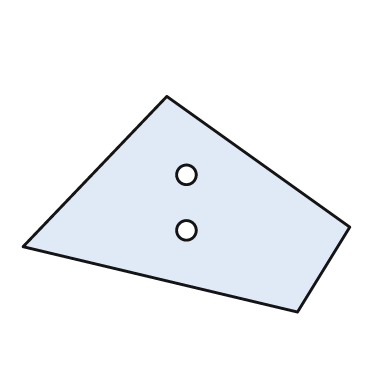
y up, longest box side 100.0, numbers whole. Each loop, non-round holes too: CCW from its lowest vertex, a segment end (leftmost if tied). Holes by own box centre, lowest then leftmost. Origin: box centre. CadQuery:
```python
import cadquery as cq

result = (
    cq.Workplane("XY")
    .moveTo(34.0, -33.0)
    .lineTo(50.0, -7.0)
    .lineTo(-6.0, 33.0)
    .lineTo(-50.0, -13.0)
    .close()
    .moveTo(0.0, -8.0)
    .circle(3.0)
    .moveTo(0.0, 9.0)
    .circle(3.0)
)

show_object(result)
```